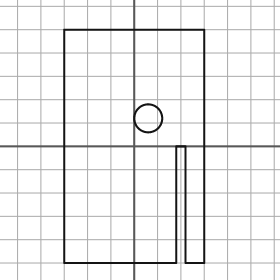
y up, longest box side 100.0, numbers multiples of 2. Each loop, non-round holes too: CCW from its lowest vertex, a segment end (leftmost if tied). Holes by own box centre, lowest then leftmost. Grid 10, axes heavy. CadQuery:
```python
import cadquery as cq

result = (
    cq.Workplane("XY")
    .moveTo(-30.0, -50.0)
    .lineTo(18.0, -50.0)
    .lineTo(18.0, 0.0)
    .lineTo(22.0, 0.0)
    .lineTo(22.0, -50.0)
    .lineTo(30.0, -50.0)
    .lineTo(30.0, 50.0)
    .lineTo(-30.0, 50.0)
    .close()
    .moveTo(6.0, 12.0)
    .circle(6.0)
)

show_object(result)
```